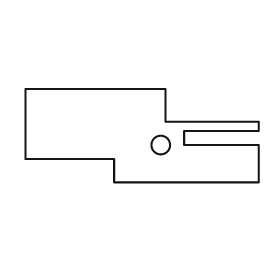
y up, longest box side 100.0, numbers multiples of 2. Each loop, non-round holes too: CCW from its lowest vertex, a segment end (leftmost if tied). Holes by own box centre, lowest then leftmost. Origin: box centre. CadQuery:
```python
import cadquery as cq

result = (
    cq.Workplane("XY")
    .moveTo(-12.0, -20.0)
    .lineTo(50.0, -20.0)
    .lineTo(50.0, -4.0)
    .lineTo(18.0, -4.0)
    .lineTo(18.0, 2.0)
    .lineTo(50.0, 2.0)
    .lineTo(50.0, 6.0)
    .lineTo(10.0, 6.0)
    .lineTo(10.0, 20.0)
    .lineTo(-50.0, 20.0)
    .lineTo(-50.0, -10.0)
    .lineTo(-12.0, -10.0)
    .close()
    .moveTo(8.0, -4.0)
    .circle(4.0)
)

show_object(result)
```